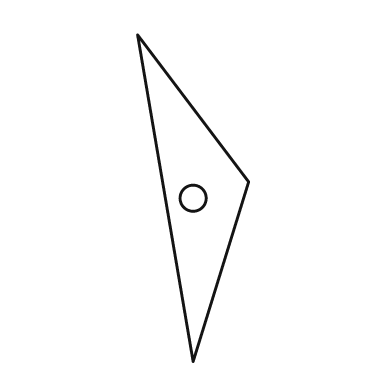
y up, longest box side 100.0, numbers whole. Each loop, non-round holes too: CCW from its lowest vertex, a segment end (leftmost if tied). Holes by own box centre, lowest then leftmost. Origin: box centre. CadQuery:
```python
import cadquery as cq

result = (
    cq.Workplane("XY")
    .moveTo(0.0, -50.0)
    .lineTo(17.0, 5.0)
    .lineTo(-17.0, 50.0)
    .close()
    .moveTo(0.0, 0.0)
    .circle(4.0)
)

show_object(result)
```